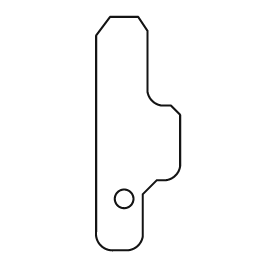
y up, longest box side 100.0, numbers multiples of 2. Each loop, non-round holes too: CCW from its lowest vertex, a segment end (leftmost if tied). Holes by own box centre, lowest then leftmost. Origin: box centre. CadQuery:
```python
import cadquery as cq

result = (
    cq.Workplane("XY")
    .moveTo(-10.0, -50.0)
    .lineTo(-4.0, -50.0)
    .threePointArc((0.0, -48.0), (2.0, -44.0))
    .lineTo(2.0, -26.0)
    .lineTo(8.0, -20.0)
    .lineTo(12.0, -20.0)
    .threePointArc((16.0, -18.0), (18.0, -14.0))
    .lineTo(18.0, 8.0)
    .lineTo(14.0, 12.0)
    .lineTo(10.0, 12.0)
    .threePointArc((6.0, 14.0), (4.0, 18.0))
    .lineTo(4.0, 44.0)
    .lineTo(0.0, 50.0)
    .lineTo(-12.0, 50.0)
    .lineTo(-18.0, 42.0)
    .lineTo(-18.0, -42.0)
    .threePointArc((-16.0, -48.0), (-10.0, -50.0))
    .close()
    .moveTo(-6.0, -28.0)
    .circle(4.0)
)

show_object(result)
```